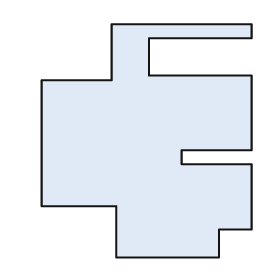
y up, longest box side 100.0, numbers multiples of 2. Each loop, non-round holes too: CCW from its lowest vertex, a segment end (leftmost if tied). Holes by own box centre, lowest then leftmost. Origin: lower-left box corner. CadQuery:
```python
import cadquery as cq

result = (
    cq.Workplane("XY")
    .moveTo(32.0, 0.0)
    .lineTo(76.0, 0.0)
    .lineTo(76.0, 12.0)
    .lineTo(90.0, 12.0)
    .lineTo(90.0, 40.0)
    .lineTo(60.0, 40.0)
    .lineTo(60.0, 46.0)
    .lineTo(90.0, 46.0)
    .lineTo(90.0, 78.0)
    .lineTo(46.0, 78.0)
    .lineTo(46.0, 94.0)
    .lineTo(90.0, 94.0)
    .lineTo(90.0, 100.0)
    .lineTo(30.0, 100.0)
    .lineTo(30.0, 76.0)
    .lineTo(0.0, 76.0)
    .lineTo(0.0, 22.0)
    .lineTo(32.0, 22.0)
    .close()
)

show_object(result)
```